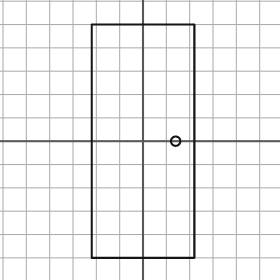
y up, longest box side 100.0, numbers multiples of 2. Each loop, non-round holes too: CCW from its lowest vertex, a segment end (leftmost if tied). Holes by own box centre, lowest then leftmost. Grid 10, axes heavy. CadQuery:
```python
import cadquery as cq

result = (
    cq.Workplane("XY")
    .moveTo(-22.0, -50.0)
    .lineTo(22.0, -50.0)
    .lineTo(22.0, 50.0)
    .lineTo(-22.0, 50.0)
    .close()
    .moveTo(14.0, 0.0)
    .circle(2.0)
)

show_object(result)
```